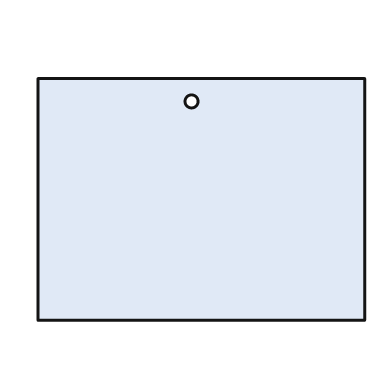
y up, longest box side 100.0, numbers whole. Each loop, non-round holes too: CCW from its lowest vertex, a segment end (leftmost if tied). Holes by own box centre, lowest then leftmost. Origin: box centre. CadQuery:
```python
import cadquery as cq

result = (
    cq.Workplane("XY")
    .moveTo(-50.0, -37.0)
    .lineTo(50.0, -37.0)
    .lineTo(50.0, 37.0)
    .lineTo(-50.0, 37.0)
    .close()
    .moveTo(-3.0, 30.0)
    .circle(2.0)
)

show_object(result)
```